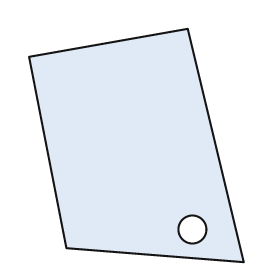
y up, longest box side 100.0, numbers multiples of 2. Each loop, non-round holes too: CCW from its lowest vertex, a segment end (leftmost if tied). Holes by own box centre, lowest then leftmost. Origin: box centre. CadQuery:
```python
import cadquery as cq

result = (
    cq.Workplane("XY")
    .moveTo(46.0, -50.0)
    .lineTo(22.0, 50.0)
    .lineTo(-46.0, 38.0)
    .lineTo(-30.0, -44.0)
    .close()
    .moveTo(24.0, -36.0)
    .circle(6.0)
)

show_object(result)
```